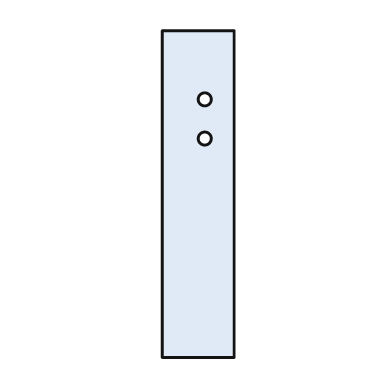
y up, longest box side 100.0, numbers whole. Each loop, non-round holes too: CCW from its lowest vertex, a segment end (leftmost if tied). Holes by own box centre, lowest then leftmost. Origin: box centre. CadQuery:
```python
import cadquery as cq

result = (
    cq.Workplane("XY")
    .moveTo(-11.0, -50.0)
    .lineTo(11.0, -50.0)
    .lineTo(11.0, 50.0)
    .lineTo(-11.0, 50.0)
    .close()
    .moveTo(2.0, 17.0)
    .circle(2.0)
    .moveTo(2.0, 29.0)
    .circle(2.0)
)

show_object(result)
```